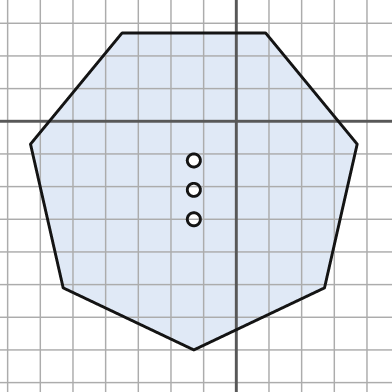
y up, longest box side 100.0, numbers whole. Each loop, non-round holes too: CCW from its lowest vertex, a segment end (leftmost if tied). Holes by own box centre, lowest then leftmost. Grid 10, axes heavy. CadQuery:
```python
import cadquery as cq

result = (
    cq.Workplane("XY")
    .moveTo(-13.0, -70.0)
    .lineTo(27.0, -51.0)
    .lineTo(37.0, -7.0)
    .lineTo(9.0, 27.0)
    .lineTo(-35.0, 27.0)
    .lineTo(-63.0, -7.0)
    .lineTo(-53.0, -51.0)
    .close()
    .moveTo(-13.0, -30.0)
    .circle(2.0)
    .moveTo(-13.0, -21.0)
    .circle(2.0)
    .moveTo(-13.0, -12.0)
    .circle(2.0)
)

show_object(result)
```